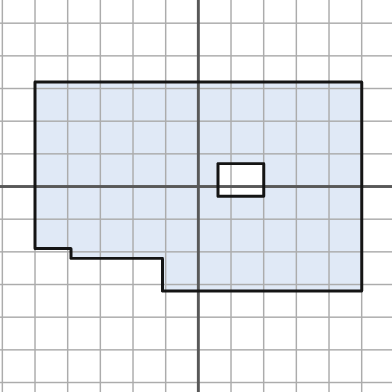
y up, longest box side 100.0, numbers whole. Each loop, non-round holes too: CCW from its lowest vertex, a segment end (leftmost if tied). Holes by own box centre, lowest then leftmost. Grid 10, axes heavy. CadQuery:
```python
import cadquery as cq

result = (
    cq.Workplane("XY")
    .moveTo(-11.0, -32.0)
    .lineTo(50.0, -32.0)
    .lineTo(50.0, 32.0)
    .lineTo(-50.0, 32.0)
    .lineTo(-50.0, -19.0)
    .lineTo(-39.0, -19.0)
    .lineTo(-39.0, -22.0)
    .lineTo(-11.0, -22.0)
    .close()
    .moveTo(6.0, -3.0)
    .lineTo(20.0, -3.0)
    .lineTo(20.0, 7.0)
    .lineTo(6.0, 7.0)
    .close()
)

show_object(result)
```